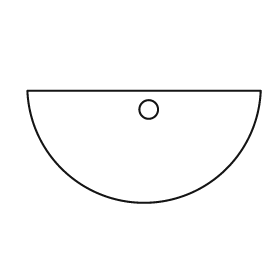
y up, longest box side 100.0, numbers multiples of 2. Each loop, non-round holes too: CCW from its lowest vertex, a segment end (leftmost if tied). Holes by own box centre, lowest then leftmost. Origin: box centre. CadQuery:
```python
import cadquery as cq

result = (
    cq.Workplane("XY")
    .moveTo(-50.0, 24.0)
    .threePointArc((0.0, -24.0), (50.0, 24.0))
    .close()
    .moveTo(2.0, 16.0)
    .circle(4.0)
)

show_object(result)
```